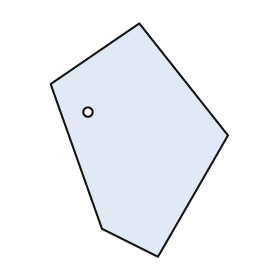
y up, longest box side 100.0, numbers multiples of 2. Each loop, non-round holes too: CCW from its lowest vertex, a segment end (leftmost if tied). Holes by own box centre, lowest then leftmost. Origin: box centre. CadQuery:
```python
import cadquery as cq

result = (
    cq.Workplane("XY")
    .moveTo(8.0, -50.0)
    .lineTo(38.0, 2.0)
    .lineTo(0.0, 50.0)
    .lineTo(-38.0, 24.0)
    .lineTo(-16.0, -38.0)
    .close()
    .moveTo(-22.0, 12.0)
    .circle(2.0)
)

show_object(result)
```